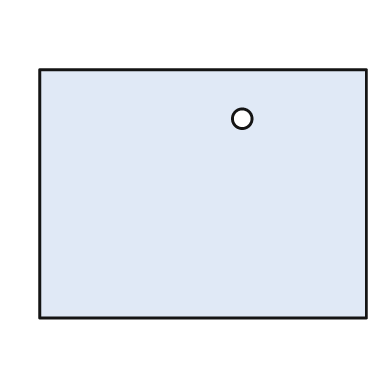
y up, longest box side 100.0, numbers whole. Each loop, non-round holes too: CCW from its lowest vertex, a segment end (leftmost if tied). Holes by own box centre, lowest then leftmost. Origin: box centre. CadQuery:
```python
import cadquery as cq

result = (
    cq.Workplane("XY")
    .moveTo(-50.0, -38.0)
    .lineTo(50.0, -38.0)
    .lineTo(50.0, 38.0)
    .lineTo(-50.0, 38.0)
    .close()
    .moveTo(12.0, 23.0)
    .circle(3.0)
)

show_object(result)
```